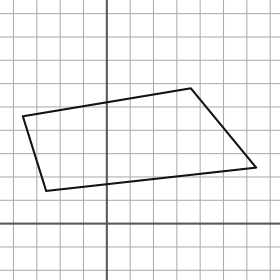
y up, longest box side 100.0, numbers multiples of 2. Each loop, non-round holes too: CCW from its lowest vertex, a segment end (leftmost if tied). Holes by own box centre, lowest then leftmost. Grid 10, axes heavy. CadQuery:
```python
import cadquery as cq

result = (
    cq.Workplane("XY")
    .moveTo(-26.0, 14.0)
    .lineTo(64.0, 24.0)
    .lineTo(36.0, 58.0)
    .lineTo(-36.0, 46.0)
    .close()
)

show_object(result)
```